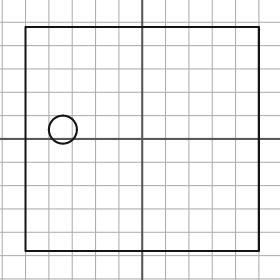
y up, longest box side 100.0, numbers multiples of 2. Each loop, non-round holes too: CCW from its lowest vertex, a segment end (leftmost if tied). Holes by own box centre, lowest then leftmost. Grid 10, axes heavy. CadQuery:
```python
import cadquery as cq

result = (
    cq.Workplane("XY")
    .moveTo(-50.0, -48.0)
    .lineTo(50.0, -48.0)
    .lineTo(50.0, 48.0)
    .lineTo(-50.0, 48.0)
    .close()
    .moveTo(-34.0, 4.0)
    .circle(6.0)
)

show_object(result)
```